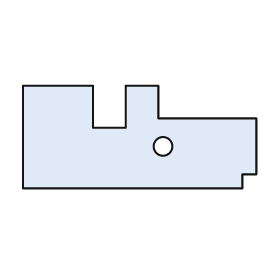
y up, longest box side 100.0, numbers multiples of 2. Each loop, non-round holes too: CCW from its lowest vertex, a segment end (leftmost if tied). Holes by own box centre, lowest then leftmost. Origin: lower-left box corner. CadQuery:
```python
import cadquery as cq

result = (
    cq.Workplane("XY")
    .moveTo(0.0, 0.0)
    .lineTo(94.0, 0.0)
    .lineTo(94.0, 6.0)
    .lineTo(100.0, 6.0)
    .lineTo(100.0, 30.0)
    .lineTo(58.0, 30.0)
    .lineTo(58.0, 44.0)
    .lineTo(44.0, 44.0)
    .lineTo(44.0, 26.0)
    .lineTo(30.0, 26.0)
    .lineTo(30.0, 44.0)
    .lineTo(0.0, 44.0)
    .close()
    .moveTo(60.0, 18.0)
    .circle(4.0)
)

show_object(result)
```